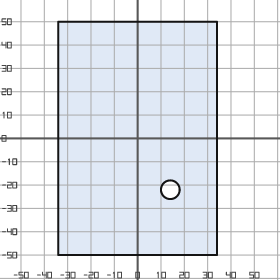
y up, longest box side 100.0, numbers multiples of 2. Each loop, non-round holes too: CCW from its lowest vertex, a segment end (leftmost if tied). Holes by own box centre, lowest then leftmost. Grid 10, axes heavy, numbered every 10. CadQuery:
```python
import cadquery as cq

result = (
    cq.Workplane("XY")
    .moveTo(-34.0, -50.0)
    .lineTo(34.0, -50.0)
    .lineTo(34.0, 50.0)
    .lineTo(-34.0, 50.0)
    .close()
    .moveTo(14.0, -22.0)
    .circle(4.0)
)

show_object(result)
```